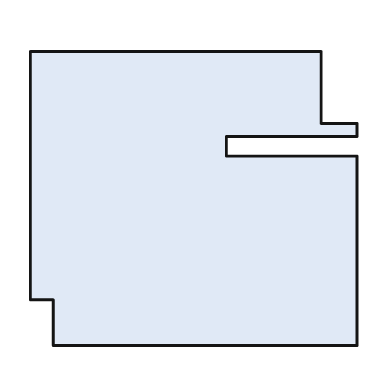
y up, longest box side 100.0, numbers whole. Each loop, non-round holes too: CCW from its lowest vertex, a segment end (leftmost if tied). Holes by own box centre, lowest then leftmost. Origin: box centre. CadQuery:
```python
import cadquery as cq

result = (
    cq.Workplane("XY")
    .moveTo(-43.0, -45.0)
    .lineTo(50.0, -45.0)
    .lineTo(50.0, 13.0)
    .lineTo(10.0, 13.0)
    .lineTo(10.0, 19.0)
    .lineTo(50.0, 19.0)
    .lineTo(50.0, 23.0)
    .lineTo(39.0, 23.0)
    .lineTo(39.0, 45.0)
    .lineTo(-50.0, 45.0)
    .lineTo(-50.0, -31.0)
    .lineTo(-43.0, -31.0)
    .close()
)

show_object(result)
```